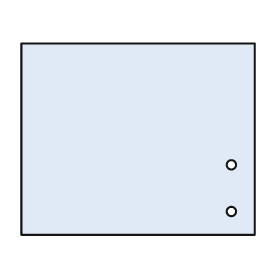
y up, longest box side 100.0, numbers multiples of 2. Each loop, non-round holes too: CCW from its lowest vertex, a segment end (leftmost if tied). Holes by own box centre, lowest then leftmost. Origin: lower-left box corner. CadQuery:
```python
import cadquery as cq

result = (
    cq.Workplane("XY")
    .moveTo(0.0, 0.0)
    .lineTo(100.0, 0.0)
    .lineTo(100.0, 82.0)
    .lineTo(0.0, 82.0)
    .close()
    .moveTo(90.0, 10.0)
    .circle(2.0)
    .moveTo(90.0, 30.0)
    .circle(2.0)
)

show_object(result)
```